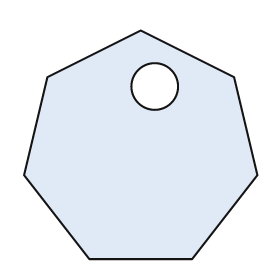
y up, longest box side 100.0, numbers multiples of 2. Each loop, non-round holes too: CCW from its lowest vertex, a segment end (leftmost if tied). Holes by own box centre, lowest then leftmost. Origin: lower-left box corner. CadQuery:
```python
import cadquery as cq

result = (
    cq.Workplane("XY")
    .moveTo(28.0, 0.0)
    .lineTo(72.0, 0.0)
    .lineTo(100.0, 36.0)
    .lineTo(90.0, 78.0)
    .lineTo(50.0, 98.0)
    .lineTo(10.0, 78.0)
    .lineTo(0.0, 36.0)
    .close()
    .moveTo(56.0, 74.0)
    .circle(10.0)
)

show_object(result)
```